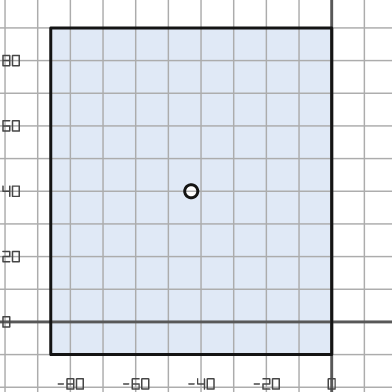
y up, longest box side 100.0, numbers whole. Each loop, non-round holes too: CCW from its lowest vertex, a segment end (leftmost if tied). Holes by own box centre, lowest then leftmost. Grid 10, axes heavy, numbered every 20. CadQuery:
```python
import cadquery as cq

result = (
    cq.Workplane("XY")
    .moveTo(-86.0, -10.0)
    .lineTo(0.0, -10.0)
    .lineTo(0.0, 90.0)
    .lineTo(-86.0, 90.0)
    .close()
    .moveTo(-43.0, 40.0)
    .circle(2.0)
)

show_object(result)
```